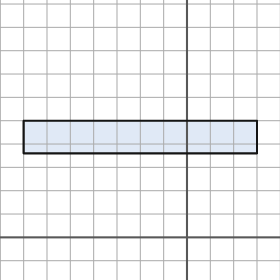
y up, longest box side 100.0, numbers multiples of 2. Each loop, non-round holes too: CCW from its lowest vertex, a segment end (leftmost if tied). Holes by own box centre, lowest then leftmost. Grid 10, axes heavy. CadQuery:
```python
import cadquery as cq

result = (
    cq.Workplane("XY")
    .moveTo(-70.0, 36.0)
    .lineTo(30.0, 36.0)
    .lineTo(30.0, 50.0)
    .lineTo(-70.0, 50.0)
    .close()
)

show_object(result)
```